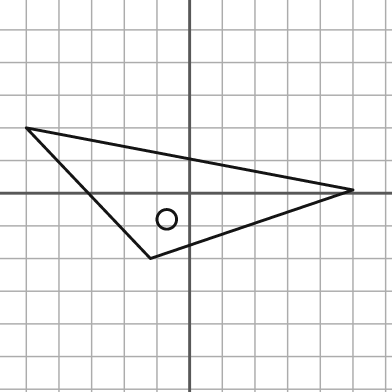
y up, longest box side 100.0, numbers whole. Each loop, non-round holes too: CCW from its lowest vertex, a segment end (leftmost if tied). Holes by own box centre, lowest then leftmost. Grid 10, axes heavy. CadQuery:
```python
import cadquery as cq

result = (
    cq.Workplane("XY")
    .moveTo(-12.0, -20.0)
    .lineTo(50.0, 1.0)
    .lineTo(-50.0, 20.0)
    .close()
    .moveTo(-7.0, -8.0)
    .circle(3.0)
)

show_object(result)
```